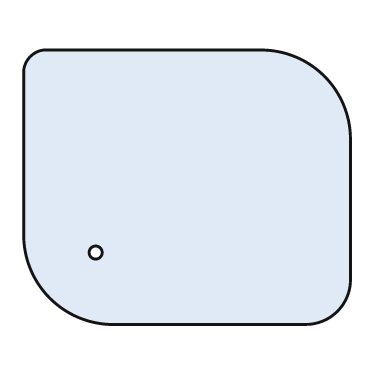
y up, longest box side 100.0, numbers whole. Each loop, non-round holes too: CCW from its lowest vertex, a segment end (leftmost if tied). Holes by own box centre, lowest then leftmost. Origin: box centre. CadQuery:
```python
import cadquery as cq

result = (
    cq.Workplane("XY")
    .moveTo(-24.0, -42.0)
    .lineTo(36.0, -42.0)
    .threePointArc((46.0, -38.0), (50.0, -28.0))
    .lineTo(50.0, 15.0)
    .threePointArc((42.0, 34.0), (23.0, 42.0))
    .lineTo(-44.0, 42.0)
    .threePointArc((-48.0, 40.0), (-50.0, 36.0))
    .lineTo(-50.0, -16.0)
    .threePointArc((-42.0, -34.0), (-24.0, -42.0))
    .close()
    .moveTo(-28.0, -20.0)
    .circle(2.0)
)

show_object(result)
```